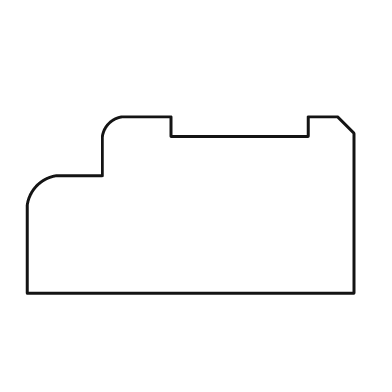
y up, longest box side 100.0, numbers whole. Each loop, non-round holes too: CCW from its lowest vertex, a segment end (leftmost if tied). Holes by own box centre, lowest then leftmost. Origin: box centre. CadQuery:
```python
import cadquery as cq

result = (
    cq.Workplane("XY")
    .moveTo(-50.0, -27.0)
    .lineTo(50.0, -27.0)
    .lineTo(50.0, 22.0)
    .lineTo(45.0, 27.0)
    .lineTo(36.0, 27.0)
    .lineTo(36.0, 21.0)
    .lineTo(-6.0, 21.0)
    .lineTo(-6.0, 27.0)
    .lineTo(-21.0, 27.0)
    .threePointArc((-25.0, 25.0), (-27.0, 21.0))
    .lineTo(-27.0, 9.0)
    .lineTo(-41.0, 9.0)
    .threePointArc((-47.0, 6.0), (-50.0, 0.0))
    .close()
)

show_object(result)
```